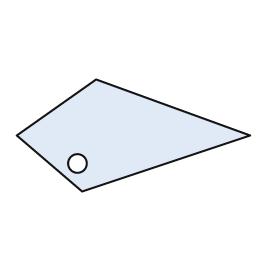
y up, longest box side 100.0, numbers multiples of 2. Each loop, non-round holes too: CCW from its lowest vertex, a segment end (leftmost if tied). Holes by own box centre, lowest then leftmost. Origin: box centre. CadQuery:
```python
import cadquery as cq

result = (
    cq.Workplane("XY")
    .moveTo(-22.0, -24.0)
    .lineTo(50.0, 0.0)
    .lineTo(-16.0, 24.0)
    .lineTo(-50.0, 0.0)
    .close()
    .moveTo(-24.0, -12.0)
    .circle(4.0)
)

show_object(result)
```